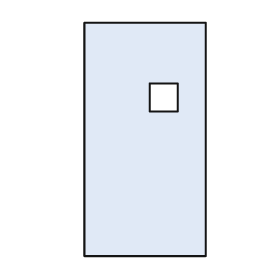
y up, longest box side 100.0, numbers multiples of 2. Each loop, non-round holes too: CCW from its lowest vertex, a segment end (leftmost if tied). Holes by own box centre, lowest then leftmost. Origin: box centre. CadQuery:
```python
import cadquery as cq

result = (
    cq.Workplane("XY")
    .moveTo(-26.0, -50.0)
    .lineTo(26.0, -50.0)
    .lineTo(26.0, 50.0)
    .lineTo(-26.0, 50.0)
    .close()
    .moveTo(2.0, 12.0)
    .lineTo(14.0, 12.0)
    .lineTo(14.0, 24.0)
    .lineTo(2.0, 24.0)
    .close()
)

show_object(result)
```